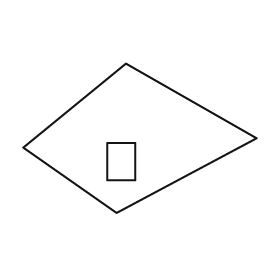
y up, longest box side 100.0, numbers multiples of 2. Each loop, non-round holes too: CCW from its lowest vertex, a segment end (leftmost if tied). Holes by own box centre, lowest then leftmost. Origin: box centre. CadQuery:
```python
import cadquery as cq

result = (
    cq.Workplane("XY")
    .moveTo(-10.0, -32.0)
    .lineTo(50.0, 0.0)
    .lineTo(-6.0, 32.0)
    .lineTo(-50.0, -4.0)
    .close()
    .moveTo(-14.0, -18.0)
    .lineTo(-2.0, -18.0)
    .lineTo(-2.0, -2.0)
    .lineTo(-14.0, -2.0)
    .close()
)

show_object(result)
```